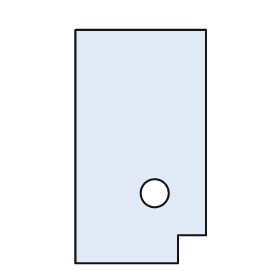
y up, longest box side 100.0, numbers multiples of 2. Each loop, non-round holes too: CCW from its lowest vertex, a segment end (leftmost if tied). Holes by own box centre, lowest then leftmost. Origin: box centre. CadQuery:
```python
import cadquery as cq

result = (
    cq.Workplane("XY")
    .moveTo(-28.0, -50.0)
    .lineTo(16.0, -50.0)
    .lineTo(16.0, -38.0)
    .lineTo(28.0, -38.0)
    .lineTo(28.0, 50.0)
    .lineTo(-28.0, 50.0)
    .close()
    .moveTo(6.0, -20.0)
    .circle(6.0)
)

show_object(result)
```